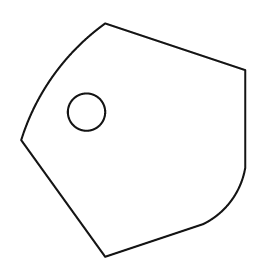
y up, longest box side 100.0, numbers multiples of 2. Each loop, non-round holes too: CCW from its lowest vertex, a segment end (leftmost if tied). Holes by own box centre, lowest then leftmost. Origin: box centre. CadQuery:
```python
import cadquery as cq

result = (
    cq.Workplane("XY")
    .moveTo(-12.0, -50.0)
    .lineTo(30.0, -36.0)
    .threePointArc((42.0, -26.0), (48.0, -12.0))
    .lineTo(48.0, 30.0)
    .lineTo(-12.0, 50.0)
    .threePointArc((-34.0, 28.0), (-48.0, 0.0))
    .close()
    .moveTo(-20.0, 12.0)
    .circle(8.0)
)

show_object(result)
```